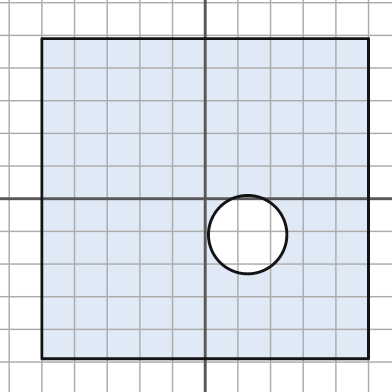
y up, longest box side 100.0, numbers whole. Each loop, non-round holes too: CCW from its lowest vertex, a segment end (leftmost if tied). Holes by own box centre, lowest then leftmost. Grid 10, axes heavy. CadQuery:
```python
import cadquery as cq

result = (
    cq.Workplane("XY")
    .moveTo(-50.0, -49.0)
    .lineTo(50.0, -49.0)
    .lineTo(50.0, 49.0)
    .lineTo(-50.0, 49.0)
    .close()
    .moveTo(13.0, -11.0)
    .circle(12.0)
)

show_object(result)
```